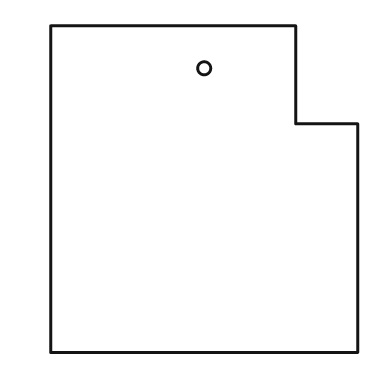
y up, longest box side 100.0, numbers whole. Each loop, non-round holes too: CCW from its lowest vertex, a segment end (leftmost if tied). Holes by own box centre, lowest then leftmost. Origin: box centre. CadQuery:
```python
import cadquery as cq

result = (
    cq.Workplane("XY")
    .moveTo(-47.0, -50.0)
    .lineTo(47.0, -50.0)
    .lineTo(47.0, 20.0)
    .lineTo(28.0, 20.0)
    .lineTo(28.0, 50.0)
    .lineTo(-47.0, 50.0)
    .close()
    .moveTo(0.0, 37.0)
    .circle(2.0)
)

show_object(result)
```